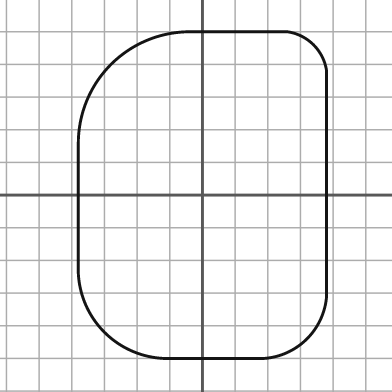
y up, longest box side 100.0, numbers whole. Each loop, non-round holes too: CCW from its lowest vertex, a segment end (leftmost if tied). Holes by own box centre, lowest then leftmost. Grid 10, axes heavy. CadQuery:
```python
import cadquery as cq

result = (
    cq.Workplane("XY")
    .moveTo(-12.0, -50.0)
    .lineTo(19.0, -50.0)
    .threePointArc((32.0, -44.0), (38.0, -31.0))
    .lineTo(38.0, 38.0)
    .threePointArc((34.0, 46.0), (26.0, 50.0))
    .lineTo(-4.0, 50.0)
    .threePointArc((-28.0, 40.0), (-38.0, 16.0))
    .lineTo(-38.0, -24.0)
    .threePointArc((-30.0, -42.0), (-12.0, -50.0))
    .close()
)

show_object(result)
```